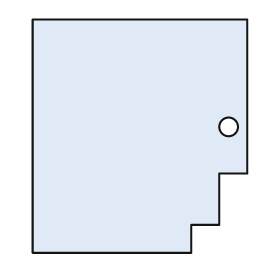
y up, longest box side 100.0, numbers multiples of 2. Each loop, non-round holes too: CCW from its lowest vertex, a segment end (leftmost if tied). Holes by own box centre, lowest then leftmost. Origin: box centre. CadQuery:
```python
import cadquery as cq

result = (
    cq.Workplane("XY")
    .moveTo(-46.0, -50.0)
    .lineTo(22.0, -50.0)
    .lineTo(22.0, -38.0)
    .lineTo(34.0, -38.0)
    .lineTo(34.0, -16.0)
    .lineTo(46.0, -16.0)
    .lineTo(46.0, 50.0)
    .lineTo(-46.0, 50.0)
    .close()
    .moveTo(38.0, 4.0)
    .circle(4.0)
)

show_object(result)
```